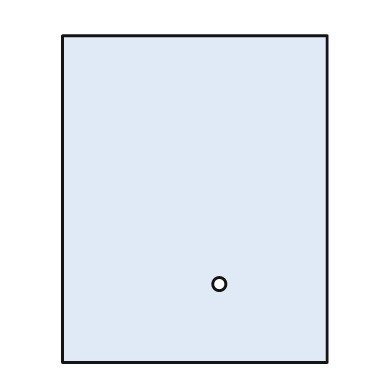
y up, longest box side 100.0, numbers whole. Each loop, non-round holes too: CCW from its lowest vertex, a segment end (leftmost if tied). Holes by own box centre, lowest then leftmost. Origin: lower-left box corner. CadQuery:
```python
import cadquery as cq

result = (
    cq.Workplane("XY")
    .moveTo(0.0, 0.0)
    .lineTo(81.0, 0.0)
    .lineTo(81.0, 100.0)
    .lineTo(0.0, 100.0)
    .close()
    .moveTo(48.0, 24.0)
    .circle(2.0)
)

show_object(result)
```